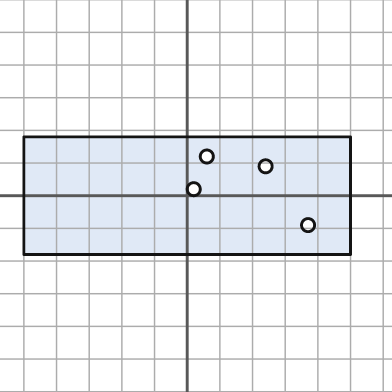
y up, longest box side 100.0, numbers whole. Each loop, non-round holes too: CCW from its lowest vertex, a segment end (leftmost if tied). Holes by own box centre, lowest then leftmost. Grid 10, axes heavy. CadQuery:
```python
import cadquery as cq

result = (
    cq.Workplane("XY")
    .moveTo(-50.0, -18.0)
    .lineTo(50.0, -18.0)
    .lineTo(50.0, 18.0)
    .lineTo(-50.0, 18.0)
    .close()
    .moveTo(37.0, -9.0)
    .circle(2.0)
    .moveTo(2.0, 2.0)
    .circle(2.0)
    .moveTo(24.0, 9.0)
    .circle(2.0)
    .moveTo(6.0, 12.0)
    .circle(2.0)
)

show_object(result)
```